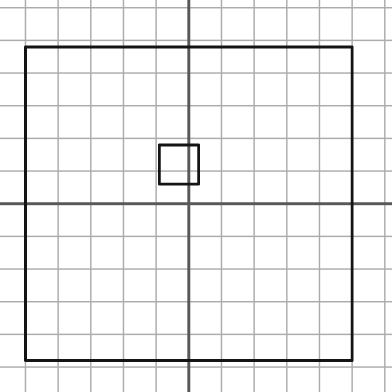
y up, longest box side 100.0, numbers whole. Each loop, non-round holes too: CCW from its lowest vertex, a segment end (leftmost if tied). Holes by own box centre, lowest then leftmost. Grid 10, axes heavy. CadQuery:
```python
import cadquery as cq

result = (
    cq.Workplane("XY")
    .moveTo(-50.0, -48.0)
    .lineTo(50.0, -48.0)
    .lineTo(50.0, 48.0)
    .lineTo(-50.0, 48.0)
    .close()
    .moveTo(-9.0, 6.0)
    .lineTo(3.0, 6.0)
    .lineTo(3.0, 18.0)
    .lineTo(-9.0, 18.0)
    .close()
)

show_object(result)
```